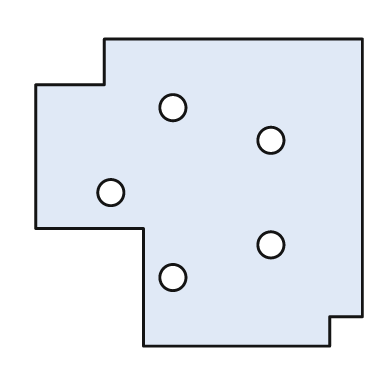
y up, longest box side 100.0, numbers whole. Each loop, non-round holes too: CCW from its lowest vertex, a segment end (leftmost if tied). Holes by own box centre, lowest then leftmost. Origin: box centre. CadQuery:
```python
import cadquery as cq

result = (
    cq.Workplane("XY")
    .moveTo(-17.0, -47.0)
    .lineTo(40.0, -47.0)
    .lineTo(40.0, -38.0)
    .lineTo(50.0, -38.0)
    .lineTo(50.0, 47.0)
    .lineTo(-29.0, 47.0)
    .lineTo(-29.0, 33.0)
    .lineTo(-50.0, 33.0)
    .lineTo(-50.0, -11.0)
    .lineTo(-17.0, -11.0)
    .close()
    .moveTo(-8.0, -26.0)
    .circle(4.0)
    .moveTo(22.0, -16.0)
    .circle(4.0)
    .moveTo(-27.0, 0.0)
    .circle(4.0)
    .moveTo(22.0, 16.0)
    .circle(4.0)
    .moveTo(-8.0, 26.0)
    .circle(4.0)
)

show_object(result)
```